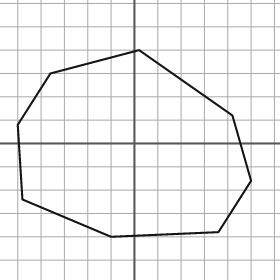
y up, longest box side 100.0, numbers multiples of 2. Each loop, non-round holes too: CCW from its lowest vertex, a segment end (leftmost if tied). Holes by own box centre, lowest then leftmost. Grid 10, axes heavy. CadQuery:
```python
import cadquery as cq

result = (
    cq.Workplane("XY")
    .moveTo(-10.0, -40.0)
    .lineTo(36.0, -38.0)
    .lineTo(50.0, -16.0)
    .lineTo(42.0, 12.0)
    .lineTo(2.0, 40.0)
    .lineTo(-36.0, 30.0)
    .lineTo(-50.0, 8.0)
    .lineTo(-48.0, -24.0)
    .close()
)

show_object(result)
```